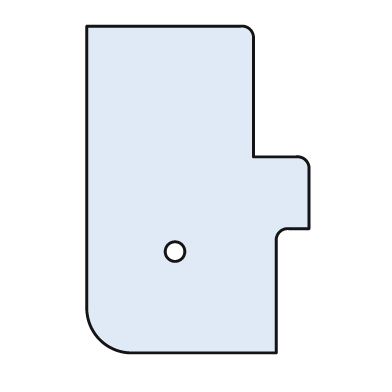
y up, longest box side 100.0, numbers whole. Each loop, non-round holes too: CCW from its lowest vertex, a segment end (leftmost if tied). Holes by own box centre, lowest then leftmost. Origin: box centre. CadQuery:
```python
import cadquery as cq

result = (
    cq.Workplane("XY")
    .moveTo(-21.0, -50.0)
    .lineTo(24.0, -50.0)
    .lineTo(24.0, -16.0)
    .threePointArc((25.0, -13.0), (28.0, -12.0))
    .lineTo(34.0, -12.0)
    .lineTo(34.0, 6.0)
    .threePointArc((33.0, 9.0), (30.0, 10.0))
    .lineTo(17.0, 10.0)
    .lineTo(17.0, 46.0)
    .threePointArc((16.0, 49.0), (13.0, 50.0))
    .lineTo(-34.0, 50.0)
    .lineTo(-34.0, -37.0)
    .threePointArc((-30.0, -46.0), (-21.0, -50.0))
    .close()
    .moveTo(-7.0, -19.0)
    .circle(3.0)
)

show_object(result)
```